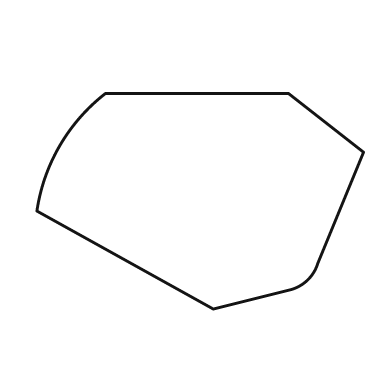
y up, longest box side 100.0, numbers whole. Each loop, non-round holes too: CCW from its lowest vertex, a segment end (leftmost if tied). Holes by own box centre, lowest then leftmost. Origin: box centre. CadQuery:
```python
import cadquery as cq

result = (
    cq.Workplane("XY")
    .moveTo(4.0, -33.0)
    .lineTo(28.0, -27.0)
    .threePointArc((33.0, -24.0), (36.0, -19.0))
    .lineTo(50.0, 15.0)
    .lineTo(27.0, 33.0)
    .lineTo(-29.0, 33.0)
    .threePointArc((-43.0, 17.0), (-50.0, -3.0))
    .close()
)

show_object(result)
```